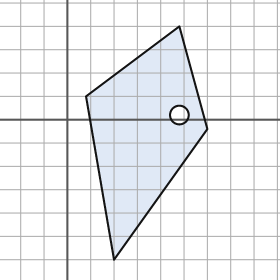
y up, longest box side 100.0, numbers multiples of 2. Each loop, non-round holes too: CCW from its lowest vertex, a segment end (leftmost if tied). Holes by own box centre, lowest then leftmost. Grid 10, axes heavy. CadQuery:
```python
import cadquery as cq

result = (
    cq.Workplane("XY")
    .moveTo(20.0, -60.0)
    .lineTo(60.0, -4.0)
    .lineTo(48.0, 40.0)
    .lineTo(8.0, 10.0)
    .close()
    .moveTo(48.0, 2.0)
    .circle(4.0)
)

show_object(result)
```